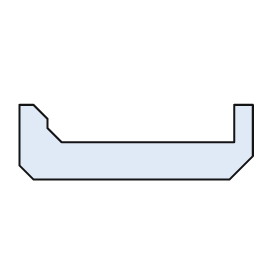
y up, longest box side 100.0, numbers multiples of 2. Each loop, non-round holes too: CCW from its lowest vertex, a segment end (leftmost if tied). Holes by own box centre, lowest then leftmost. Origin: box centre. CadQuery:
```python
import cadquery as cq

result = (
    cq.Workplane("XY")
    .moveTo(-44.0, -16.0)
    .lineTo(40.0, -16.0)
    .lineTo(50.0, -6.0)
    .lineTo(50.0, 16.0)
    .lineTo(42.0, 16.0)
    .lineTo(42.0, 0.0)
    .lineTo(-32.0, 0.0)
    .lineTo(-38.0, 6.0)
    .lineTo(-38.0, 10.0)
    .lineTo(-44.0, 16.0)
    .lineTo(-50.0, 16.0)
    .lineTo(-50.0, -10.0)
    .close()
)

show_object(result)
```